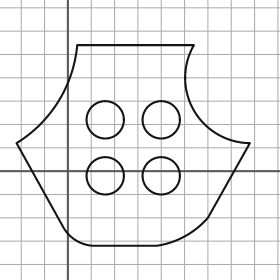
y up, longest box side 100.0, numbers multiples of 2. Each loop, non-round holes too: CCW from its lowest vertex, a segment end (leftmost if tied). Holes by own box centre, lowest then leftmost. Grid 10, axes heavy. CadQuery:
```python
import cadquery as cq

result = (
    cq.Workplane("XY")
    .moveTo(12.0, -32.0)
    .lineTo(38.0, -32.0)
    .threePointArc((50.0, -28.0), (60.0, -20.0))
    .lineTo(78.0, 12.0)
    .threePointArc((54.0, 26.0), (54.0, 54.0))
    .lineTo(4.0, 54.0)
    .threePointArc((-4.0, 30.0), (-22.0, 12.0))
    .lineTo(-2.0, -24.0)
    .threePointArc((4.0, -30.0), (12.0, -32.0))
    .close()
    .moveTo(16.0, -2.0)
    .circle(8.0)
    .moveTo(40.0, -2.0)
    .circle(8.0)
    .moveTo(16.0, 22.0)
    .circle(8.0)
    .moveTo(40.0, 22.0)
    .circle(8.0)
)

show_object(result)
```